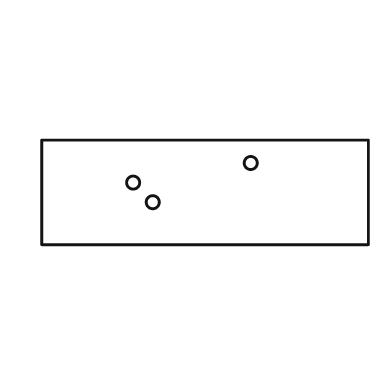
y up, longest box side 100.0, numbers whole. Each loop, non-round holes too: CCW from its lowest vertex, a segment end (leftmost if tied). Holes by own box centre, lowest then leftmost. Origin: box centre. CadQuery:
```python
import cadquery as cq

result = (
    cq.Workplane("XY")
    .moveTo(-50.0, -16.0)
    .lineTo(50.0, -16.0)
    .lineTo(50.0, 16.0)
    .lineTo(-50.0, 16.0)
    .close()
    .moveTo(-16.0, -3.0)
    .circle(2.0)
    .moveTo(-22.0, 3.0)
    .circle(2.0)
    .moveTo(14.0, 9.0)
    .circle(2.0)
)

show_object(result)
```